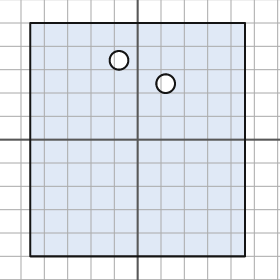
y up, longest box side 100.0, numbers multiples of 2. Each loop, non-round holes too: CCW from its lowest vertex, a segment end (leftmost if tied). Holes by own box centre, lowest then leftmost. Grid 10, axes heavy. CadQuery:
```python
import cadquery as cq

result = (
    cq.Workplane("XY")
    .moveTo(-46.0, -50.0)
    .lineTo(46.0, -50.0)
    .lineTo(46.0, 50.0)
    .lineTo(-46.0, 50.0)
    .close()
    .moveTo(12.0, 24.0)
    .circle(4.0)
    .moveTo(-8.0, 34.0)
    .circle(4.0)
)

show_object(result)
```